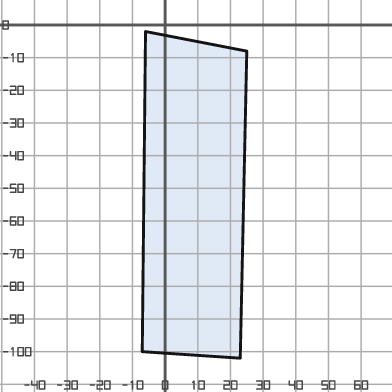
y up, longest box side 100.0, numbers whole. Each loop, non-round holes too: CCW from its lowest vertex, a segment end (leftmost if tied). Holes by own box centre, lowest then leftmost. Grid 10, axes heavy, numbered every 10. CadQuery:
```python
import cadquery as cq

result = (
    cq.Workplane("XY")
    .moveTo(23.0, -102.0)
    .lineTo(25.0, -8.0)
    .lineTo(-6.0, -2.0)
    .lineTo(-7.0, -100.0)
    .close()
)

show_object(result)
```